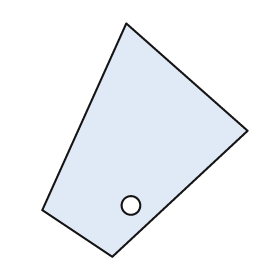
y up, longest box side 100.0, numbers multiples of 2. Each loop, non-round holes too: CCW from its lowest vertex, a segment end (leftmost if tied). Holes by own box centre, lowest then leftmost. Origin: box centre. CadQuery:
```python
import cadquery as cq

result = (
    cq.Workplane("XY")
    .moveTo(-14.0, -50.0)
    .lineTo(44.0, 4.0)
    .lineTo(-8.0, 50.0)
    .lineTo(-44.0, -30.0)
    .close()
    .moveTo(-6.0, -28.0)
    .circle(4.0)
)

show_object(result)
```